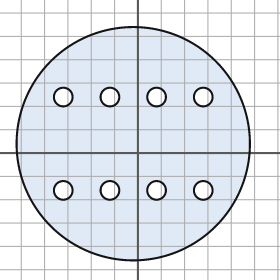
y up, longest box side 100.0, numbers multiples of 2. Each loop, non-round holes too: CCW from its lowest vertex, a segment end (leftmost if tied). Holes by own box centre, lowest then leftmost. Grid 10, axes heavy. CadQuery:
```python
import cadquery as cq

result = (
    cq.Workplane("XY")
    .moveTo(-2.0, 4.0)
    .circle(50.0)
    .moveTo(-32.0, -16.0)
    .circle(4.0)
    .moveTo(-12.0, -16.0)
    .circle(4.0)
    .moveTo(8.0, -16.0)
    .circle(4.0)
    .moveTo(28.0, -16.0)
    .circle(4.0)
    .moveTo(-32.0, 24.0)
    .circle(4.0)
    .moveTo(-12.0, 24.0)
    .circle(4.0)
    .moveTo(8.0, 24.0)
    .circle(4.0)
    .moveTo(28.0, 24.0)
    .circle(4.0)
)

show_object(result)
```